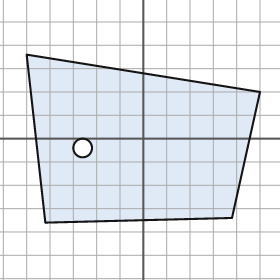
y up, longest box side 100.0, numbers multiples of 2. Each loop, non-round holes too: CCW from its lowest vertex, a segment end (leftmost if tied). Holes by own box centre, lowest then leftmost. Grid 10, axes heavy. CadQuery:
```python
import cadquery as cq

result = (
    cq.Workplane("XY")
    .moveTo(-42.0, -36.0)
    .lineTo(38.0, -34.0)
    .lineTo(50.0, 20.0)
    .lineTo(-50.0, 36.0)
    .close()
    .moveTo(-26.0, -4.0)
    .circle(4.0)
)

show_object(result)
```